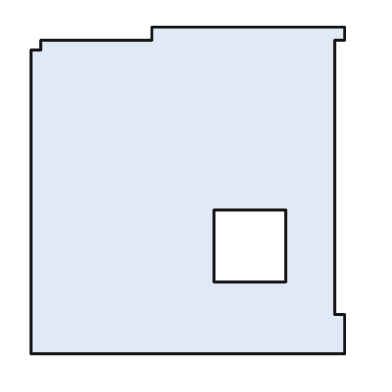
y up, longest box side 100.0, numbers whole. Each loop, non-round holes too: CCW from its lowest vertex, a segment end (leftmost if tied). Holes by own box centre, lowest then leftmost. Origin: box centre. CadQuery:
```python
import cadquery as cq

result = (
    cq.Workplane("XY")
    .moveTo(-48.0, -50.0)
    .lineTo(48.0, -50.0)
    .lineTo(48.0, -38.0)
    .lineTo(45.0, -38.0)
    .lineTo(45.0, 46.0)
    .lineTo(48.0, 46.0)
    .lineTo(48.0, 50.0)
    .lineTo(-11.0, 50.0)
    .lineTo(-11.0, 46.0)
    .lineTo(-45.0, 46.0)
    .lineTo(-45.0, 43.0)
    .lineTo(-48.0, 43.0)
    .close()
    .moveTo(8.0, -28.0)
    .lineTo(30.0, -28.0)
    .lineTo(30.0, -6.0)
    .lineTo(8.0, -6.0)
    .close()
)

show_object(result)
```